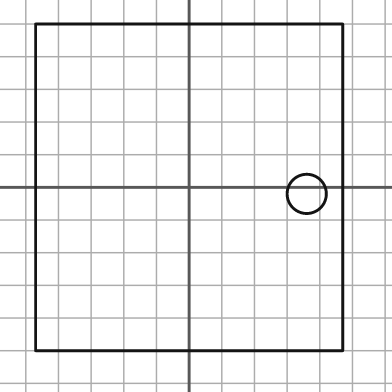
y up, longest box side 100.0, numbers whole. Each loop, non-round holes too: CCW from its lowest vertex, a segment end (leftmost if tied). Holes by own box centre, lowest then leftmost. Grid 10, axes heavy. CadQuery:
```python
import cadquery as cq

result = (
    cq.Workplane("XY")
    .moveTo(-47.0, -50.0)
    .lineTo(47.0, -50.0)
    .lineTo(47.0, 50.0)
    .lineTo(-47.0, 50.0)
    .close()
    .moveTo(36.0, -2.0)
    .circle(6.0)
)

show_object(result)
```